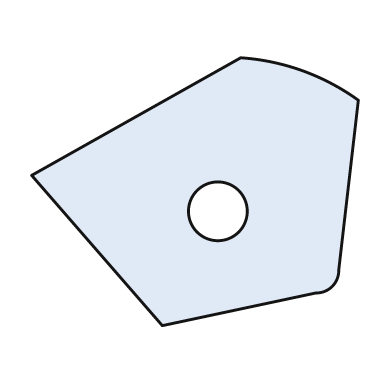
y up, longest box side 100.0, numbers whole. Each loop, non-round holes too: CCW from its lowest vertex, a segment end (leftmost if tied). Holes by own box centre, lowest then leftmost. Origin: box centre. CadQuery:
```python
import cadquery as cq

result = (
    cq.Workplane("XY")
    .moveTo(-10.0, -41.0)
    .lineTo(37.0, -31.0)
    .threePointArc((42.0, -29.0), (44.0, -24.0))
    .lineTo(50.0, 28.0)
    .threePointArc((33.0, 37.0), (14.0, 41.0))
    .lineTo(-50.0, 5.0)
    .close()
    .moveTo(7.0, -6.0)
    .circle(9.0)
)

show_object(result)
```